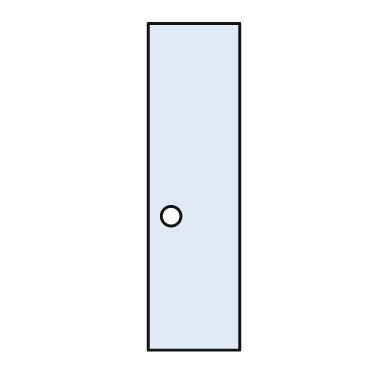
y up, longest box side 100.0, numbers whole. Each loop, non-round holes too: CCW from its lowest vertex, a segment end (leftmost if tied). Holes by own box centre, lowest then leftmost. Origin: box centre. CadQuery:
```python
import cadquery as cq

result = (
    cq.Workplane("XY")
    .moveTo(-14.0, -50.0)
    .lineTo(14.0, -50.0)
    .lineTo(14.0, 50.0)
    .lineTo(-14.0, 50.0)
    .close()
    .moveTo(-7.0, -9.0)
    .circle(3.0)
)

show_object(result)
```